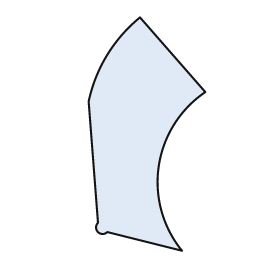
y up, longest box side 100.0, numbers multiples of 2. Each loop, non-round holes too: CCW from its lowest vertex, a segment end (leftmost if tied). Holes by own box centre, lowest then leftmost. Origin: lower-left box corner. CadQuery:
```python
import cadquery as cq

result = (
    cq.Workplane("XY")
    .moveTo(40.0, 0.0)
    .threePointArc((30.0, 36.0), (50.0, 68.0))
    .lineTo(22.0, 100.0)
    .threePointArc((8.0, 84.0), (0.0, 64.0))
    .lineTo(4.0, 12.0)
    .threePointArc((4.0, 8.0), (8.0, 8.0))
    .close()
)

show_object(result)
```